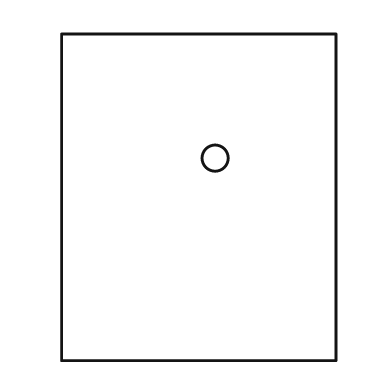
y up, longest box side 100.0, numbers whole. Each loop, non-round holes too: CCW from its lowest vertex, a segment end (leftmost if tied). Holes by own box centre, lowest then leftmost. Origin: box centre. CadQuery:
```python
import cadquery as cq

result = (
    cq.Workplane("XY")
    .moveTo(-42.0, -50.0)
    .lineTo(42.0, -50.0)
    .lineTo(42.0, 50.0)
    .lineTo(-42.0, 50.0)
    .close()
    .moveTo(5.0, 12.0)
    .circle(4.0)
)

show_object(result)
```